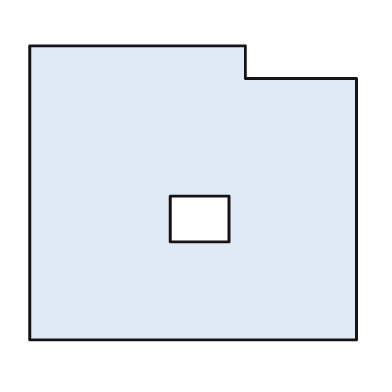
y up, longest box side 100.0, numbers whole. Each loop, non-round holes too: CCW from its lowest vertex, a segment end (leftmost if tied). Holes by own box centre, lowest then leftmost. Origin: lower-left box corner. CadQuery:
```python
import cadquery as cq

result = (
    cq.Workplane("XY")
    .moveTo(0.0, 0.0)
    .lineTo(100.0, 0.0)
    .lineTo(100.0, 80.0)
    .lineTo(66.0, 80.0)
    .lineTo(66.0, 90.0)
    .lineTo(0.0, 90.0)
    .close()
    .moveTo(43.0, 30.0)
    .lineTo(61.0, 30.0)
    .lineTo(61.0, 44.0)
    .lineTo(43.0, 44.0)
    .close()
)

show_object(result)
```